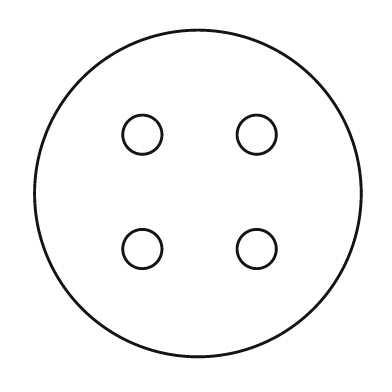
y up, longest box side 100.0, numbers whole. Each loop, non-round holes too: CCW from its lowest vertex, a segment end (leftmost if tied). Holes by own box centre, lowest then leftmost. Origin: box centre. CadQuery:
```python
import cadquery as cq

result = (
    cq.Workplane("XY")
    .moveTo(0.0, 0.0)
    .circle(50.0)
    .moveTo(-17.0, -17.0)
    .circle(6.0)
    .moveTo(18.0, -17.0)
    .circle(6.0)
    .moveTo(-17.0, 18.0)
    .circle(6.0)
    .moveTo(18.0, 18.0)
    .circle(6.0)
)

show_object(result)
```